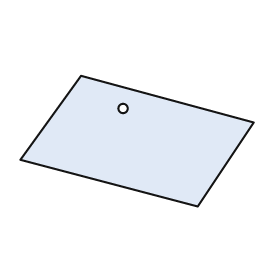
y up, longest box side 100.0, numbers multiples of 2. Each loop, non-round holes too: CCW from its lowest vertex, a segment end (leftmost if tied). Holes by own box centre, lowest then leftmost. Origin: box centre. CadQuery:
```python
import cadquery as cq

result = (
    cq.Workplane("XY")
    .moveTo(26.0, -28.0)
    .lineTo(50.0, 8.0)
    .lineTo(-24.0, 28.0)
    .lineTo(-50.0, -8.0)
    .close()
    .moveTo(-6.0, 14.0)
    .circle(2.0)
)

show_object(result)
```